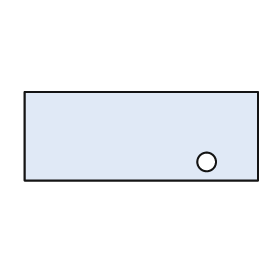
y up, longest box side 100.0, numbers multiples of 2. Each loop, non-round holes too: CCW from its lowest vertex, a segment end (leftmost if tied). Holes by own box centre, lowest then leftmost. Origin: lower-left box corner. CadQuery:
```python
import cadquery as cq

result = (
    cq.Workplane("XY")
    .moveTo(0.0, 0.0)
    .lineTo(100.0, 0.0)
    .lineTo(100.0, 38.0)
    .lineTo(0.0, 38.0)
    .close()
    .moveTo(78.0, 8.0)
    .circle(4.0)
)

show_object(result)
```